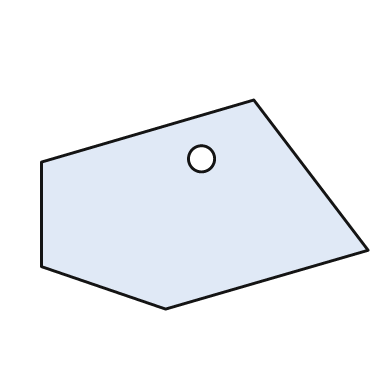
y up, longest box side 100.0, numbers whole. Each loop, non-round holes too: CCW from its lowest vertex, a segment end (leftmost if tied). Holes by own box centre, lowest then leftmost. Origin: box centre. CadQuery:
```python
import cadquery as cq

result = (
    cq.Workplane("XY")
    .moveTo(-12.0, -32.0)
    .lineTo(50.0, -14.0)
    .lineTo(15.0, 32.0)
    .lineTo(-50.0, 13.0)
    .lineTo(-50.0, -19.0)
    .close()
    .moveTo(-1.0, 14.0)
    .circle(4.0)
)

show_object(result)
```